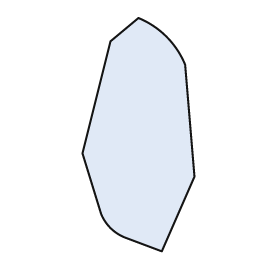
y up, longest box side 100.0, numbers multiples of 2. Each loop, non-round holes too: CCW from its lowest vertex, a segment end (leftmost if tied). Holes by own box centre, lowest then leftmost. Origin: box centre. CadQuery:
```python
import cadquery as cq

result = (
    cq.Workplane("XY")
    .moveTo(10.0, -50.0)
    .lineTo(24.0, -18.0)
    .lineTo(20.0, 30.0)
    .threePointArc((12.0, 42.0), (0.0, 50.0))
    .lineTo(-12.0, 40.0)
    .lineTo(-24.0, -8.0)
    .lineTo(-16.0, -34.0)
    .threePointArc((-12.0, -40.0), (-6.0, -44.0))
    .close()
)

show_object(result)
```